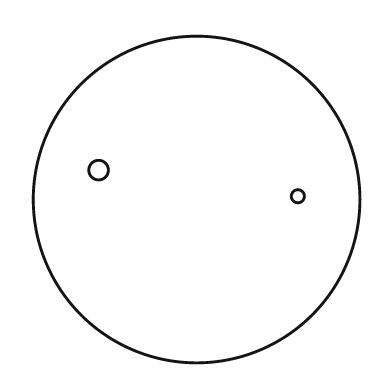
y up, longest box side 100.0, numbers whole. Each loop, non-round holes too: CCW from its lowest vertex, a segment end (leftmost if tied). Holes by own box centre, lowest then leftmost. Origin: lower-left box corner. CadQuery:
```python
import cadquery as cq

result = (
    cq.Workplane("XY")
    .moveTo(50.0, 50.0)
    .circle(50.0)
    .moveTo(81.0, 51.0)
    .circle(2.0)
    .moveTo(20.0, 59.0)
    .circle(3.0)
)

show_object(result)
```